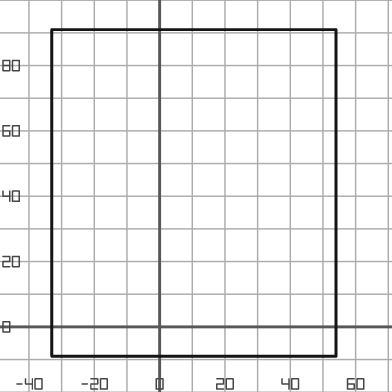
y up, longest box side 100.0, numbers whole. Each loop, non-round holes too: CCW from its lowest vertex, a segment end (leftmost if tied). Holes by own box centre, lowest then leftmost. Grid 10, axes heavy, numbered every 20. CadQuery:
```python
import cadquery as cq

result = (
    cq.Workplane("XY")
    .moveTo(-33.0, -9.0)
    .lineTo(54.0, -9.0)
    .lineTo(54.0, 91.0)
    .lineTo(-33.0, 91.0)
    .close()
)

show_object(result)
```